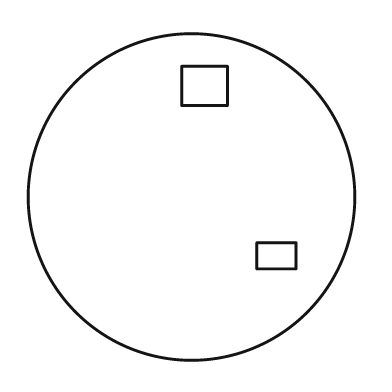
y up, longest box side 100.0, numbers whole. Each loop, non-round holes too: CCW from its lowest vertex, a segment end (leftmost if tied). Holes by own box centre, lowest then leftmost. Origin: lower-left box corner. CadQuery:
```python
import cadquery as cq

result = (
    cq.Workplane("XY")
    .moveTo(50.0, 50.0)
    .circle(50.0)
    .moveTo(70.0, 28.0)
    .lineTo(82.0, 28.0)
    .lineTo(82.0, 36.0)
    .lineTo(70.0, 36.0)
    .close()
    .moveTo(47.0, 78.0)
    .lineTo(61.0, 78.0)
    .lineTo(61.0, 90.0)
    .lineTo(47.0, 90.0)
    .close()
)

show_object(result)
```